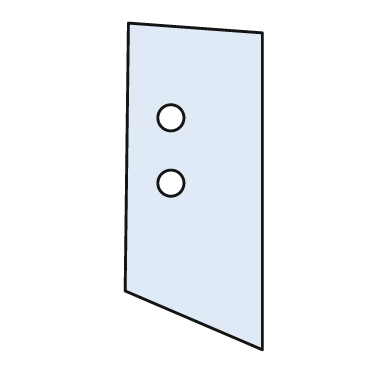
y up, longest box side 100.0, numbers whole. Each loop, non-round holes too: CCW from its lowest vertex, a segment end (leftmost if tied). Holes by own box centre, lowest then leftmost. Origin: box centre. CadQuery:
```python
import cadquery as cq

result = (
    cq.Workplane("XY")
    .moveTo(21.0, -50.0)
    .lineTo(21.0, 47.0)
    .lineTo(-20.0, 50.0)
    .lineTo(-21.0, -32.0)
    .close()
    .moveTo(-7.0, 1.0)
    .circle(4.0)
    .moveTo(-7.0, 21.0)
    .circle(4.0)
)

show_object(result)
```